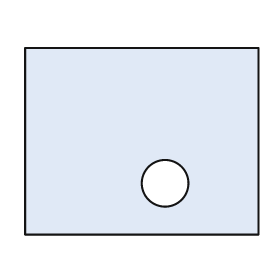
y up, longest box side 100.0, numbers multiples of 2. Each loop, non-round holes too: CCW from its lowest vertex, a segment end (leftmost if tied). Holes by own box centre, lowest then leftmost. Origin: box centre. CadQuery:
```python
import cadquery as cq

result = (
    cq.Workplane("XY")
    .moveTo(-50.0, -40.0)
    .lineTo(50.0, -40.0)
    .lineTo(50.0, 40.0)
    .lineTo(-50.0, 40.0)
    .close()
    .moveTo(10.0, -18.0)
    .circle(10.0)
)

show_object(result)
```